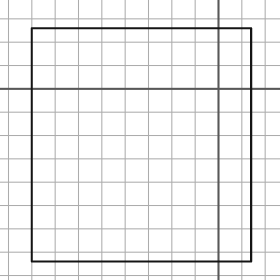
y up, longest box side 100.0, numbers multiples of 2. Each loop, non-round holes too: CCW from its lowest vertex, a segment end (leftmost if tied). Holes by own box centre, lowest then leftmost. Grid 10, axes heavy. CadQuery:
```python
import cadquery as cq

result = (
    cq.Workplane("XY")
    .moveTo(-80.0, -74.0)
    .lineTo(14.0, -74.0)
    .lineTo(14.0, 26.0)
    .lineTo(-80.0, 26.0)
    .close()
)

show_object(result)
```